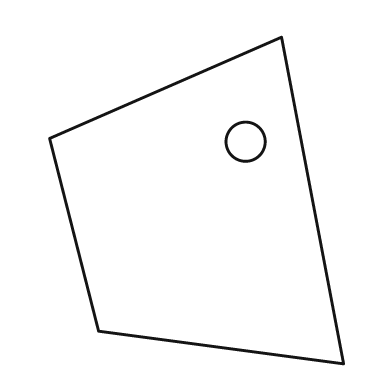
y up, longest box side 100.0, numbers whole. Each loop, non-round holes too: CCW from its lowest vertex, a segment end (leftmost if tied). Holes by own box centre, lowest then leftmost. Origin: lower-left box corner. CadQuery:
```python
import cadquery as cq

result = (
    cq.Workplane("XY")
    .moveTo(90.0, 0.0)
    .lineTo(71.0, 100.0)
    .lineTo(0.0, 69.0)
    .lineTo(15.0, 10.0)
    .close()
    .moveTo(60.0, 68.0)
    .circle(6.0)
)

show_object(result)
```